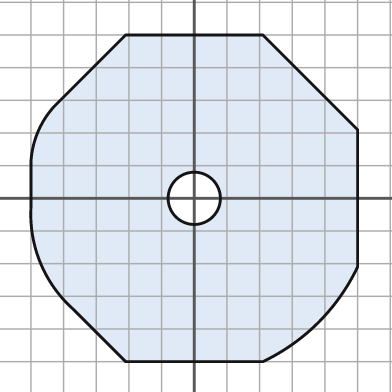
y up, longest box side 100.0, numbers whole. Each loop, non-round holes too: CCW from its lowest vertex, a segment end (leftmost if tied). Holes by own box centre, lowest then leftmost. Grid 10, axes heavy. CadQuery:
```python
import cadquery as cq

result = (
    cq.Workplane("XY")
    .moveTo(-21.0, -50.0)
    .lineTo(21.0, -50.0)
    .threePointArc((38.0, -38.0), (50.0, -21.0))
    .lineTo(50.0, 21.0)
    .lineTo(21.0, 50.0)
    .lineTo(-21.0, 50.0)
    .lineTo(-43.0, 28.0)
    .threePointArc((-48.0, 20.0), (-50.0, 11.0))
    .lineTo(-50.0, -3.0)
    .threePointArc((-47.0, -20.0), (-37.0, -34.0))
    .close()
    .moveTo(0.0, 0.0)
    .circle(8.0)
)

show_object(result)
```